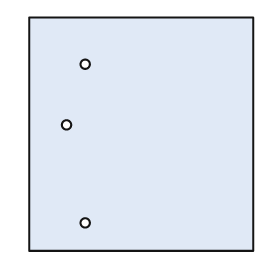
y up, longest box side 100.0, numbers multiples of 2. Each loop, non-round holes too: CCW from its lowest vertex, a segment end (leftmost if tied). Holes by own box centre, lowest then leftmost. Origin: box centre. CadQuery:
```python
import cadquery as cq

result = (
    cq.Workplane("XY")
    .moveTo(-48.0, -50.0)
    .lineTo(48.0, -50.0)
    .lineTo(48.0, 50.0)
    .lineTo(-48.0, 50.0)
    .close()
    .moveTo(-24.0, -38.0)
    .circle(2.0)
    .moveTo(-32.0, 4.0)
    .circle(2.0)
    .moveTo(-24.0, 30.0)
    .circle(2.0)
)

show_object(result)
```